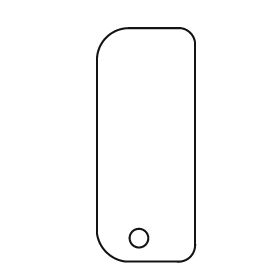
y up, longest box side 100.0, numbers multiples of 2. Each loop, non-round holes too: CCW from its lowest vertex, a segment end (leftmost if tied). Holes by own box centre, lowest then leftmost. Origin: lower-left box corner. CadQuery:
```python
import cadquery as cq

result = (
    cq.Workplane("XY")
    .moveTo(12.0, 0.0)
    .lineTo(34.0, 0.0)
    .threePointArc((40.0, 2.0), (42.0, 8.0))
    .lineTo(42.0, 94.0)
    .threePointArc((40.0, 98.0), (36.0, 100.0))
    .lineTo(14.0, 100.0)
    .threePointArc((4.0, 96.0), (0.0, 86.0))
    .lineTo(0.0, 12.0)
    .threePointArc((4.0, 4.0), (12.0, 0.0))
    .close()
    .moveTo(18.0, 10.0)
    .circle(4.0)
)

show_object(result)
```